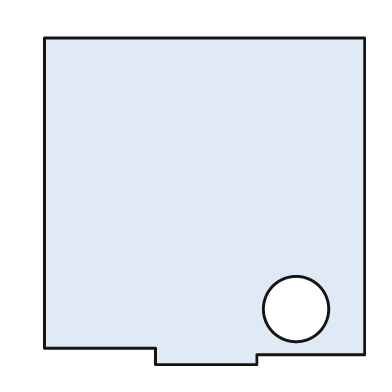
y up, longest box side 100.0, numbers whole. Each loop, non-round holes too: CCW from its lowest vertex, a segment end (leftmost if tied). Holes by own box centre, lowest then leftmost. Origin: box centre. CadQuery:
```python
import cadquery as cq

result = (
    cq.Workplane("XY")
    .moveTo(-15.0, -50.0)
    .lineTo(16.0, -50.0)
    .lineTo(16.0, -47.0)
    .lineTo(49.0, -47.0)
    .lineTo(49.0, 50.0)
    .lineTo(-49.0, 50.0)
    .lineTo(-49.0, -45.0)
    .lineTo(-15.0, -45.0)
    .close()
    .moveTo(28.0, -33.0)
    .circle(10.0)
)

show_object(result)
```